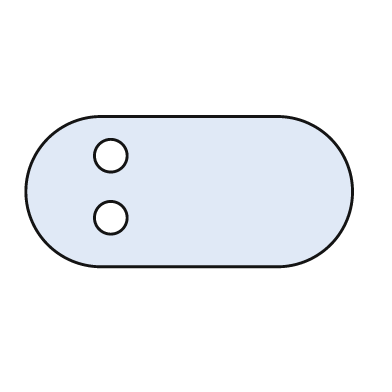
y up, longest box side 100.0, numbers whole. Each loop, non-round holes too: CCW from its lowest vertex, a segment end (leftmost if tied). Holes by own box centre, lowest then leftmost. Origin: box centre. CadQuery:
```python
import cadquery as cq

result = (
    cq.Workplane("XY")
    .moveTo(-27.0, -23.0)
    .lineTo(27.0, -23.0)
    .threePointArc((50.0, 0.0), (27.0, 23.0))
    .lineTo(-27.0, 23.0)
    .threePointArc((-50.0, 0.0), (-27.0, -23.0))
    .close()
    .moveTo(-24.0, -8.0)
    .circle(5.0)
    .moveTo(-24.0, 11.0)
    .circle(5.0)
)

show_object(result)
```